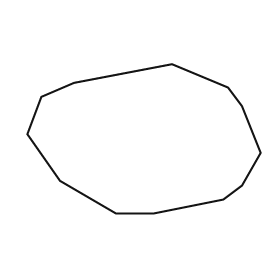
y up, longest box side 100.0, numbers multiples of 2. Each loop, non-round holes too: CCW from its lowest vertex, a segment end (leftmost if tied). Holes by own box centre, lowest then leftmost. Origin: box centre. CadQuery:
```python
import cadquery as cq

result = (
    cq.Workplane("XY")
    .moveTo(-12.0, -32.0)
    .lineTo(4.0, -32.0)
    .lineTo(34.0, -26.0)
    .lineTo(42.0, -20.0)
    .lineTo(50.0, -6.0)
    .lineTo(42.0, 14.0)
    .lineTo(36.0, 22.0)
    .lineTo(12.0, 32.0)
    .lineTo(-30.0, 24.0)
    .lineTo(-44.0, 18.0)
    .lineTo(-50.0, 2.0)
    .lineTo(-36.0, -18.0)
    .close()
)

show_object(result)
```